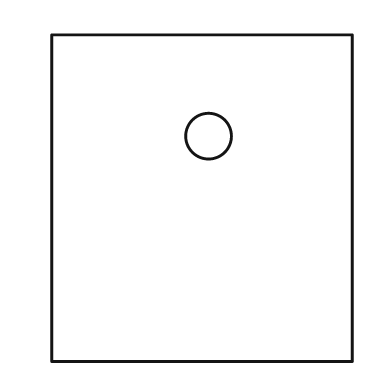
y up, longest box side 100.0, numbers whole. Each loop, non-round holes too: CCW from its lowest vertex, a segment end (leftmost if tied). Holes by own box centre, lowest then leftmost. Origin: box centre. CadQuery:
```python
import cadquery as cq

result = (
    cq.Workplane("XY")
    .moveTo(-46.0, -50.0)
    .lineTo(46.0, -50.0)
    .lineTo(46.0, 50.0)
    .lineTo(-46.0, 50.0)
    .close()
    .moveTo(2.0, 19.0)
    .circle(7.0)
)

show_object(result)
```